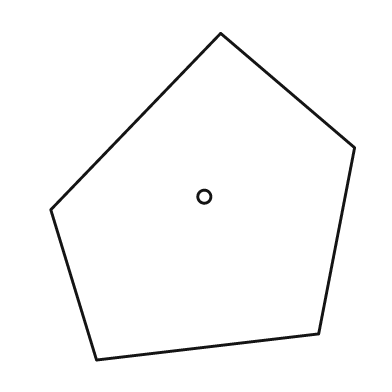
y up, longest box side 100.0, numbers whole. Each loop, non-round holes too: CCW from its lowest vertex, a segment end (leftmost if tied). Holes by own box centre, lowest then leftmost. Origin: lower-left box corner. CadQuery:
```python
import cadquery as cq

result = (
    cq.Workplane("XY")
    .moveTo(14.0, 0.0)
    .lineTo(82.0, 8.0)
    .lineTo(93.0, 65.0)
    .lineTo(52.0, 100.0)
    .lineTo(0.0, 46.0)
    .close()
    .moveTo(47.0, 50.0)
    .circle(2.0)
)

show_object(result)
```